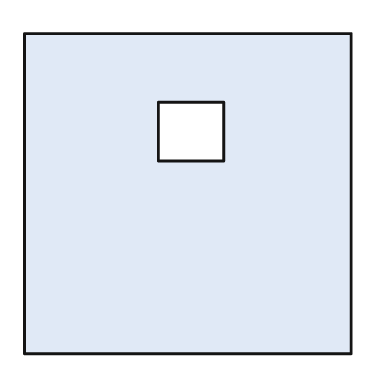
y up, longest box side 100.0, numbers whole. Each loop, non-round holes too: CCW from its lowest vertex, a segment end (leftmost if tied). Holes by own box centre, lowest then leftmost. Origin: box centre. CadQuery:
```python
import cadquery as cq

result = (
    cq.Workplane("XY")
    .moveTo(-50.0, -49.0)
    .lineTo(50.0, -49.0)
    .lineTo(50.0, 49.0)
    .lineTo(-50.0, 49.0)
    .close()
    .moveTo(-9.0, 10.0)
    .lineTo(11.0, 10.0)
    .lineTo(11.0, 28.0)
    .lineTo(-9.0, 28.0)
    .close()
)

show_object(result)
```